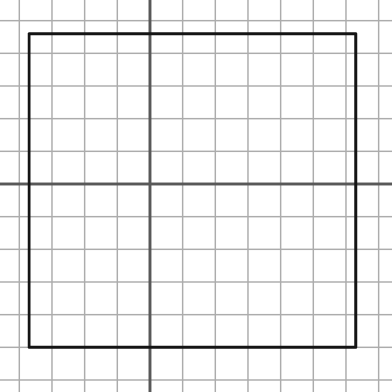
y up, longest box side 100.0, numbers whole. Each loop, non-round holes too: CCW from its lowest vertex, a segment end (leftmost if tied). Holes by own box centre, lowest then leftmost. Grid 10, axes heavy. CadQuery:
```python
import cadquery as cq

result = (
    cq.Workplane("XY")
    .moveTo(-37.0, -50.0)
    .lineTo(63.0, -50.0)
    .lineTo(63.0, 46.0)
    .lineTo(-37.0, 46.0)
    .close()
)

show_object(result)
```